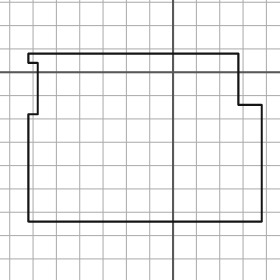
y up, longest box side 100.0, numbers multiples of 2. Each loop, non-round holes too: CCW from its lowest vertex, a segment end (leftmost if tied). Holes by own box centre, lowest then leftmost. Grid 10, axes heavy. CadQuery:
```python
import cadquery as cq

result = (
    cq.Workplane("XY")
    .moveTo(-62.0, -64.0)
    .lineTo(38.0, -64.0)
    .lineTo(38.0, -14.0)
    .lineTo(28.0, -14.0)
    .lineTo(28.0, 8.0)
    .lineTo(-62.0, 8.0)
    .lineTo(-62.0, 4.0)
    .lineTo(-58.0, 4.0)
    .lineTo(-58.0, -18.0)
    .lineTo(-62.0, -18.0)
    .close()
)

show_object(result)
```